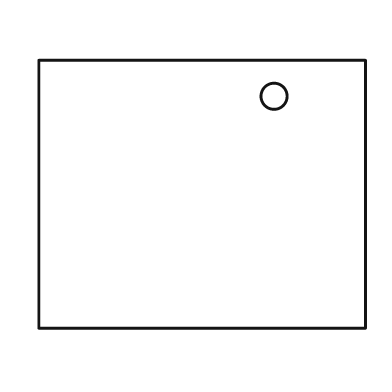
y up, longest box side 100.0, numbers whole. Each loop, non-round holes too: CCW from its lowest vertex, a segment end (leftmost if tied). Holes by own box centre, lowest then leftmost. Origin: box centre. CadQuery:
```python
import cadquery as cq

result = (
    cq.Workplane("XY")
    .moveTo(-50.0, -41.0)
    .lineTo(50.0, -41.0)
    .lineTo(50.0, 41.0)
    .lineTo(-50.0, 41.0)
    .close()
    .moveTo(22.0, 30.0)
    .circle(4.0)
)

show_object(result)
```